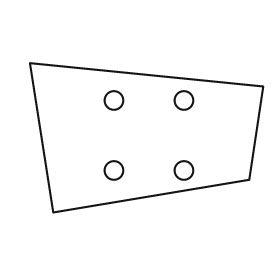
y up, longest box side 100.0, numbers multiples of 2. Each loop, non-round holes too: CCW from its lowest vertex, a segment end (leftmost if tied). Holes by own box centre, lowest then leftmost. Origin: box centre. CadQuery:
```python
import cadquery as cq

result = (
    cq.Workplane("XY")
    .moveTo(-40.0, -32.0)
    .lineTo(44.0, -18.0)
    .lineTo(50.0, 22.0)
    .lineTo(-50.0, 32.0)
    .close()
    .moveTo(-14.0, -14.0)
    .circle(4.0)
    .moveTo(16.0, -14.0)
    .circle(4.0)
    .moveTo(-14.0, 16.0)
    .circle(4.0)
    .moveTo(16.0, 16.0)
    .circle(4.0)
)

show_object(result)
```